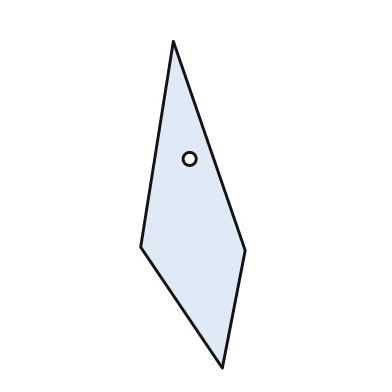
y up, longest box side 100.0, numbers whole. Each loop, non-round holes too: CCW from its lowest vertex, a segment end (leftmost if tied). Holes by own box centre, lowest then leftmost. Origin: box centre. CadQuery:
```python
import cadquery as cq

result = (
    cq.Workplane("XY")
    .moveTo(9.0, -50.0)
    .lineTo(16.0, -14.0)
    .lineTo(-6.0, 50.0)
    .lineTo(-16.0, -13.0)
    .close()
    .moveTo(-1.0, 14.0)
    .circle(2.0)
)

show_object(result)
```